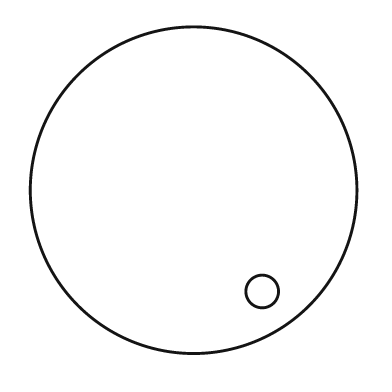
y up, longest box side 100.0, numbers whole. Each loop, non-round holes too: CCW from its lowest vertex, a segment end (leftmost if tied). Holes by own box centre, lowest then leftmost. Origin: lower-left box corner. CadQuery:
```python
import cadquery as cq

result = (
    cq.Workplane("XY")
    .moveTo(50.0, 50.0)
    .circle(50.0)
    .moveTo(71.0, 19.0)
    .circle(5.0)
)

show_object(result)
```